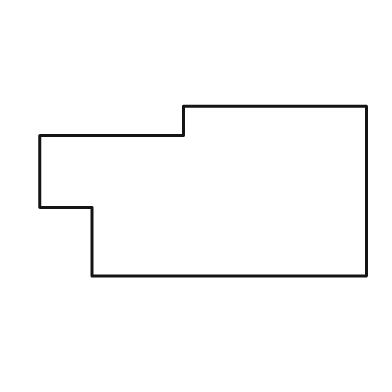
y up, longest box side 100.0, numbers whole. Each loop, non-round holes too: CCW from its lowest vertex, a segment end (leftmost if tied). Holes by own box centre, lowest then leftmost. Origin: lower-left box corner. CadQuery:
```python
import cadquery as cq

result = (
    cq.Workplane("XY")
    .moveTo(16.0, 0.0)
    .lineTo(100.0, 0.0)
    .lineTo(100.0, 52.0)
    .lineTo(44.0, 52.0)
    .lineTo(44.0, 43.0)
    .lineTo(0.0, 43.0)
    .lineTo(0.0, 21.0)
    .lineTo(16.0, 21.0)
    .close()
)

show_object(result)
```